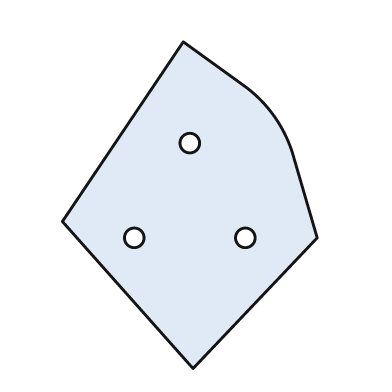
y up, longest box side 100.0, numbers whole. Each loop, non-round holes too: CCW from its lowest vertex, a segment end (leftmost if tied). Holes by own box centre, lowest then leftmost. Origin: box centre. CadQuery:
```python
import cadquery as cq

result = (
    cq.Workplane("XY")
    .moveTo(1.0, -50.0)
    .lineTo(39.0, -10.0)
    .lineTo(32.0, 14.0)
    .threePointArc((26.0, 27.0), (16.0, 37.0))
    .lineTo(-2.0, 50.0)
    .lineTo(-39.0, -5.0)
    .close()
    .moveTo(-17.0, -10.0)
    .circle(3.0)
    .moveTo(17.0, -10.0)
    .circle(3.0)
    .moveTo(0.0, 19.0)
    .circle(3.0)
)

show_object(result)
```